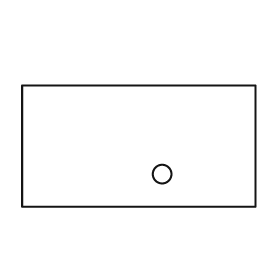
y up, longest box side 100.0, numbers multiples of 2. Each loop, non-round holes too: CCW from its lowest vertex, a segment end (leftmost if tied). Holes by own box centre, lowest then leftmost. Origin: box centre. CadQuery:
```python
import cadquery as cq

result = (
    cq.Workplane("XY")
    .moveTo(-50.0, -26.0)
    .lineTo(50.0, -26.0)
    .lineTo(50.0, 26.0)
    .lineTo(-50.0, 26.0)
    .close()
    .moveTo(10.0, -12.0)
    .circle(4.0)
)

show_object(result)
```